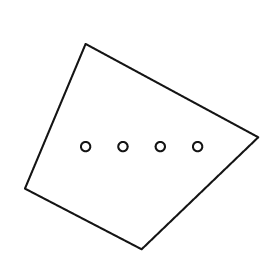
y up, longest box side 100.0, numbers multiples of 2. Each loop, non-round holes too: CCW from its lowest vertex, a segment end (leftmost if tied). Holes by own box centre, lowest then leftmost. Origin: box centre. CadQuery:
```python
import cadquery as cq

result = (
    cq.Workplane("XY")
    .moveTo(0.0, -44.0)
    .lineTo(50.0, 4.0)
    .lineTo(-24.0, 44.0)
    .lineTo(-50.0, -18.0)
    .close()
    .moveTo(-24.0, 0.0)
    .circle(2.0)
    .moveTo(-8.0, 0.0)
    .circle(2.0)
    .moveTo(8.0, 0.0)
    .circle(2.0)
    .moveTo(24.0, 0.0)
    .circle(2.0)
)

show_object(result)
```